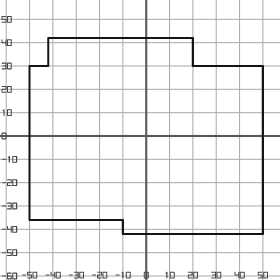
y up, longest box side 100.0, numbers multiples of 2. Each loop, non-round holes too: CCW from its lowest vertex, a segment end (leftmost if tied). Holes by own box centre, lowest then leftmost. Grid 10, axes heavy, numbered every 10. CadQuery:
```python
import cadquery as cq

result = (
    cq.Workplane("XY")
    .moveTo(-10.0, -42.0)
    .lineTo(50.0, -42.0)
    .lineTo(50.0, 30.0)
    .lineTo(20.0, 30.0)
    .lineTo(20.0, 42.0)
    .lineTo(-42.0, 42.0)
    .lineTo(-42.0, 30.0)
    .lineTo(-50.0, 30.0)
    .lineTo(-50.0, -36.0)
    .lineTo(-10.0, -36.0)
    .close()
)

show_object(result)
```